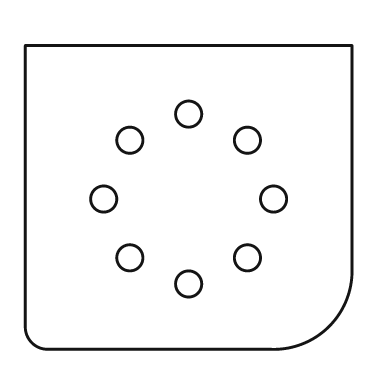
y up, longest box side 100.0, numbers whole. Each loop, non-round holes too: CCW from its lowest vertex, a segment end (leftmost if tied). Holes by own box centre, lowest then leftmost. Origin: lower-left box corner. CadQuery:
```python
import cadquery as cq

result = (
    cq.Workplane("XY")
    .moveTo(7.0, 0.0)
    .lineTo(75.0, 0.0)
    .threePointArc((93.0, 7.0), (100.0, 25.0))
    .lineTo(100.0, 93.0)
    .lineTo(0.0, 93.0)
    .lineTo(0.0, 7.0)
    .threePointArc((2.0, 2.0), (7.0, 0.0))
    .close()
    .moveTo(50.0, 20.0)
    .circle(4.0)
    .moveTo(32.0, 28.0)
    .circle(4.0)
    .moveTo(68.0, 28.0)
    .circle(4.0)
    .moveTo(24.0, 46.0)
    .circle(4.0)
    .moveTo(76.0, 46.0)
    .circle(4.0)
    .moveTo(32.0, 64.0)
    .circle(4.0)
    .moveTo(68.0, 64.0)
    .circle(4.0)
    .moveTo(50.0, 72.0)
    .circle(4.0)
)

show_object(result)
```